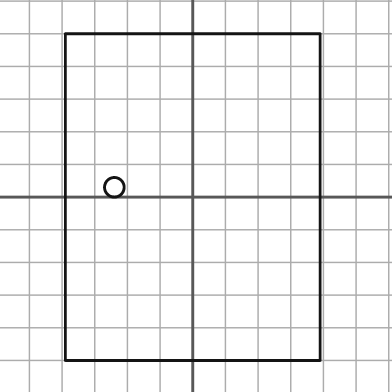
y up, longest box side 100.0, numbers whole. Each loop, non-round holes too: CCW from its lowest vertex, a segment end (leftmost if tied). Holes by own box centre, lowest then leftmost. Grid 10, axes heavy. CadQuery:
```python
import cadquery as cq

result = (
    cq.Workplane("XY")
    .moveTo(-39.0, -50.0)
    .lineTo(39.0, -50.0)
    .lineTo(39.0, 50.0)
    .lineTo(-39.0, 50.0)
    .close()
    .moveTo(-24.0, 3.0)
    .circle(3.0)
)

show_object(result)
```